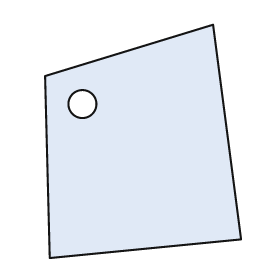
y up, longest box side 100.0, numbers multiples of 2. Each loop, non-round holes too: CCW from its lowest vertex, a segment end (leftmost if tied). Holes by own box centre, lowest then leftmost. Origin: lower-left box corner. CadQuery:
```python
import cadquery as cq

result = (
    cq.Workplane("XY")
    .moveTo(2.0, 0.0)
    .lineTo(84.0, 8.0)
    .lineTo(72.0, 100.0)
    .lineTo(0.0, 78.0)
    .close()
    .moveTo(16.0, 66.0)
    .circle(6.0)
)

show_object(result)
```